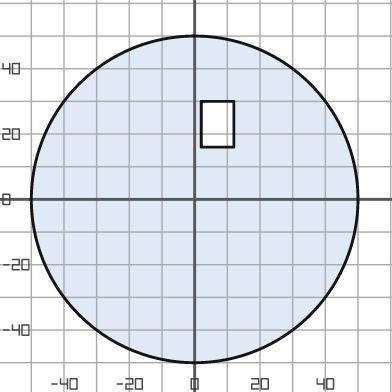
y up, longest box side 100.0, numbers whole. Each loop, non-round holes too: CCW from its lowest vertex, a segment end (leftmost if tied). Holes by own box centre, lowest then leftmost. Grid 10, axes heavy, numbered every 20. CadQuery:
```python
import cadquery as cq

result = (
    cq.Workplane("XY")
    .moveTo(0.0, 0.0)
    .circle(50.0)
    .moveTo(2.0, 16.0)
    .lineTo(12.0, 16.0)
    .lineTo(12.0, 30.0)
    .lineTo(2.0, 30.0)
    .close()
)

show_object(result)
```